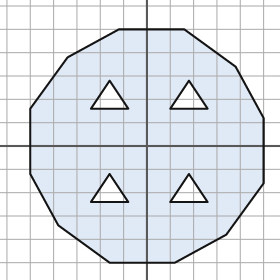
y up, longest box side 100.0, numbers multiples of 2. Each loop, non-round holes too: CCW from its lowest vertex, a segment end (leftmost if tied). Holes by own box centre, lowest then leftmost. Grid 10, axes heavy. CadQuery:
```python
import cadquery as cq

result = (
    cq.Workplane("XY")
    .moveTo(-16.0, -50.0)
    .lineTo(12.0, -50.0)
    .lineTo(34.0, -38.0)
    .lineTo(50.0, -16.0)
    .lineTo(50.0, 12.0)
    .lineTo(38.0, 34.0)
    .lineTo(16.0, 50.0)
    .lineTo(-12.0, 50.0)
    .lineTo(-34.0, 38.0)
    .lineTo(-50.0, 16.0)
    .lineTo(-50.0, -12.0)
    .lineTo(-38.0, -34.0)
    .close()
    .moveTo(-24.0, -24.0)
    .lineTo(-8.0, -24.0)
    .lineTo(-16.0, -12.0)
    .close()
    .moveTo(10.0, -24.0)
    .lineTo(26.0, -24.0)
    .lineTo(18.0, -12.0)
    .close()
    .moveTo(-24.0, 16.0)
    .lineTo(-8.0, 16.0)
    .lineTo(-16.0, 28.0)
    .close()
    .moveTo(10.0, 16.0)
    .lineTo(26.0, 16.0)
    .lineTo(18.0, 28.0)
    .close()
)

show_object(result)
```